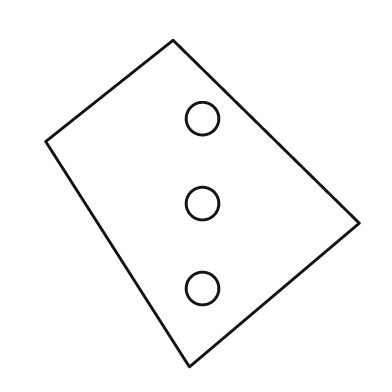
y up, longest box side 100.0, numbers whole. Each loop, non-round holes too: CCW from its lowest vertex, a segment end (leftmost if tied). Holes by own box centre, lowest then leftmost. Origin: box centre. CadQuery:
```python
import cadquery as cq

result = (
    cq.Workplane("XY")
    .moveTo(-4.0, -50.0)
    .lineTo(48.0, -6.0)
    .lineTo(-9.0, 50.0)
    .lineTo(-48.0, 19.0)
    .close()
    .moveTo(0.0, -26.0)
    .circle(5.0)
    .moveTo(0.0, 0.0)
    .circle(5.0)
    .moveTo(0.0, 26.0)
    .circle(5.0)
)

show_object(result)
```